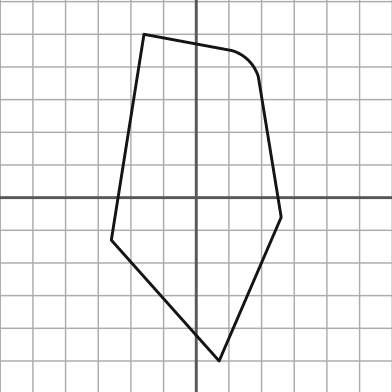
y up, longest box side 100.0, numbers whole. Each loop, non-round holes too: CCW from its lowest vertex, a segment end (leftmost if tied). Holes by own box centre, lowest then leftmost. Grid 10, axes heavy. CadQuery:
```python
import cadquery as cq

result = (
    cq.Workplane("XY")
    .moveTo(7.0, -50.0)
    .lineTo(26.0, -6.0)
    .lineTo(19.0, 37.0)
    .threePointArc((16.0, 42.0), (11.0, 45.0))
    .lineTo(-16.0, 50.0)
    .lineTo(-26.0, -13.0)
    .close()
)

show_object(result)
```